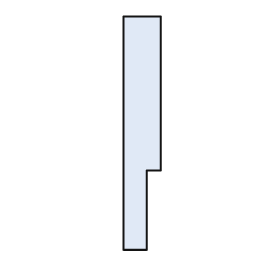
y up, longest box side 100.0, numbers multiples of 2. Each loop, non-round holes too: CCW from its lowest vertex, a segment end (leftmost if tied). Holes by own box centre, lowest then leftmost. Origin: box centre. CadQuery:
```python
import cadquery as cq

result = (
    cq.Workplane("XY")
    .moveTo(-8.0, -50.0)
    .lineTo(2.0, -50.0)
    .lineTo(2.0, -16.0)
    .lineTo(8.0, -16.0)
    .lineTo(8.0, 50.0)
    .lineTo(-8.0, 50.0)
    .close()
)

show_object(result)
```